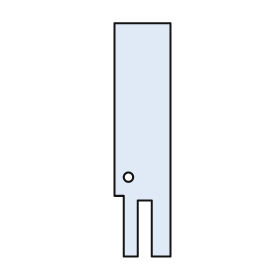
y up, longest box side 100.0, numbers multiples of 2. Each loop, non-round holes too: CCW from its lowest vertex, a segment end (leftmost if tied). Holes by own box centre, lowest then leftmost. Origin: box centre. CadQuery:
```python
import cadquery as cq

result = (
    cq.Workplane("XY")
    .moveTo(-8.0, -50.0)
    .lineTo(-2.0, -50.0)
    .lineTo(-2.0, -26.0)
    .lineTo(4.0, -26.0)
    .lineTo(4.0, -50.0)
    .lineTo(12.0, -50.0)
    .lineTo(12.0, 50.0)
    .lineTo(-12.0, 50.0)
    .lineTo(-12.0, -24.0)
    .lineTo(-8.0, -24.0)
    .close()
    .moveTo(-6.0, -16.0)
    .circle(2.0)
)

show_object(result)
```